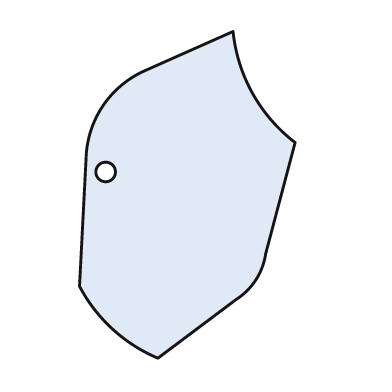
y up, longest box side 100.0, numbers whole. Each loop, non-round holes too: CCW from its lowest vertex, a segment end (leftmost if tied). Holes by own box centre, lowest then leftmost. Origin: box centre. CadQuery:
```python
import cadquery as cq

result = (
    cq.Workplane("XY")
    .moveTo(-9.0, -50.0)
    .lineTo(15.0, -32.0)
    .threePointArc((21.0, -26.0), (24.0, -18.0))
    .lineTo(33.0, 16.0)
    .threePointArc((20.0, 31.0), (14.0, 50.0))
    .lineTo(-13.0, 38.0)
    .threePointArc((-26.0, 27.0), (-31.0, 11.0))
    .lineTo(-33.0, -28.0)
    .threePointArc((-23.0, -41.0), (-9.0, -50.0))
    .close()
    .moveTo(-25.0, 7.0)
    .circle(3.0)
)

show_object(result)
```